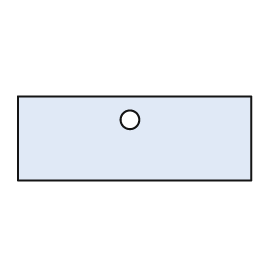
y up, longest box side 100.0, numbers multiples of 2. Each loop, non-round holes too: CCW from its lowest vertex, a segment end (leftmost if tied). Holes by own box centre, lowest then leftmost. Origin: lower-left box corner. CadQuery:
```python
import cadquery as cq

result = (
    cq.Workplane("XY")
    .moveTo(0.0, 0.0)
    .lineTo(100.0, 0.0)
    .lineTo(100.0, 36.0)
    .lineTo(0.0, 36.0)
    .close()
    .moveTo(48.0, 26.0)
    .circle(4.0)
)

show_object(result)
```